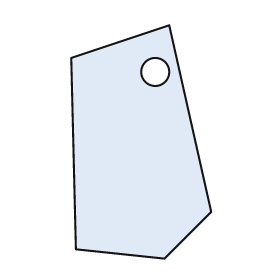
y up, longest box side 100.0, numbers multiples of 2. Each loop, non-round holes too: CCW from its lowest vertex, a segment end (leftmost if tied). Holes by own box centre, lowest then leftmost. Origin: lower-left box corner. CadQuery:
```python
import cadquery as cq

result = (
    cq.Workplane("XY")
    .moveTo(40.0, 0.0)
    .lineTo(60.0, 20.0)
    .lineTo(42.0, 100.0)
    .lineTo(0.0, 86.0)
    .lineTo(2.0, 4.0)
    .close()
    .moveTo(36.0, 80.0)
    .circle(6.0)
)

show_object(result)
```